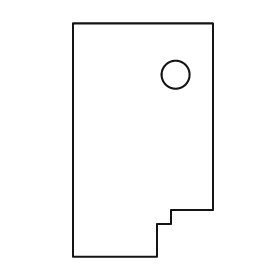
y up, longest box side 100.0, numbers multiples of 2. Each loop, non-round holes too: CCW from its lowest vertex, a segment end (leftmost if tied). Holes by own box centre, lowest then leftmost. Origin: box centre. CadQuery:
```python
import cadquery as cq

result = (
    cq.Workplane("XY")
    .moveTo(-30.0, -50.0)
    .lineTo(6.0, -50.0)
    .lineTo(6.0, -36.0)
    .lineTo(12.0, -36.0)
    .lineTo(12.0, -30.0)
    .lineTo(30.0, -30.0)
    .lineTo(30.0, 50.0)
    .lineTo(-30.0, 50.0)
    .close()
    .moveTo(14.0, 28.0)
    .circle(6.0)
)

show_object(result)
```